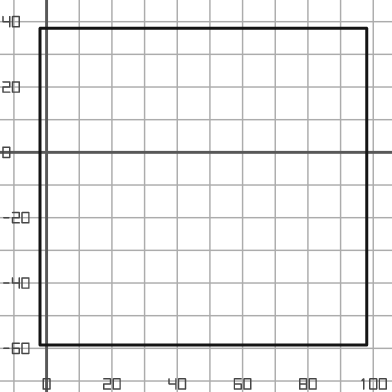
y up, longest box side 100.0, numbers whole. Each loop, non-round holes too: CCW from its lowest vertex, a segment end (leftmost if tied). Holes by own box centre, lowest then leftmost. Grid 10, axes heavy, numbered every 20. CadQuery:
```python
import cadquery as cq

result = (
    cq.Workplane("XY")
    .moveTo(-2.0, -59.0)
    .lineTo(98.0, -59.0)
    .lineTo(98.0, 38.0)
    .lineTo(-2.0, 38.0)
    .close()
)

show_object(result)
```